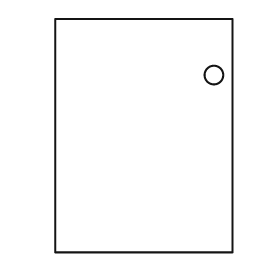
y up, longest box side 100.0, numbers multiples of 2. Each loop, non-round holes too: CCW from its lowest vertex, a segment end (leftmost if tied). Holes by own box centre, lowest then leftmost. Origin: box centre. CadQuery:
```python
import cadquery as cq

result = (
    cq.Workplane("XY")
    .moveTo(-38.0, -50.0)
    .lineTo(38.0, -50.0)
    .lineTo(38.0, 50.0)
    .lineTo(-38.0, 50.0)
    .close()
    .moveTo(30.0, 26.0)
    .circle(4.0)
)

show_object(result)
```